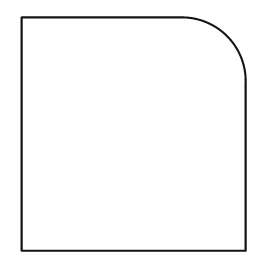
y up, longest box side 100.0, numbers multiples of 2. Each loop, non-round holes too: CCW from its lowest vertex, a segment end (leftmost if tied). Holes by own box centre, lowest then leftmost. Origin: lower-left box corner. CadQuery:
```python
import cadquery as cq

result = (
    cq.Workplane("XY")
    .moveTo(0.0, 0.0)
    .lineTo(96.0, 0.0)
    .lineTo(96.0, 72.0)
    .threePointArc((88.0, 92.0), (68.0, 100.0))
    .lineTo(0.0, 100.0)
    .close()
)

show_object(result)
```